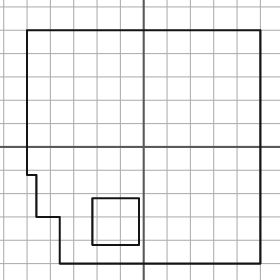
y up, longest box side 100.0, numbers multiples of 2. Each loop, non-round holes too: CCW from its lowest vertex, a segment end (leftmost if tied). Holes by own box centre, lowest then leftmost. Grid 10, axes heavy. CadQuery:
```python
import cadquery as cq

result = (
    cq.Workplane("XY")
    .moveTo(-36.0, -50.0)
    .lineTo(50.0, -50.0)
    .lineTo(50.0, 50.0)
    .lineTo(-50.0, 50.0)
    .lineTo(-50.0, -12.0)
    .lineTo(-46.0, -12.0)
    .lineTo(-46.0, -30.0)
    .lineTo(-36.0, -30.0)
    .close()
    .moveTo(-22.0, -42.0)
    .lineTo(-2.0, -42.0)
    .lineTo(-2.0, -22.0)
    .lineTo(-22.0, -22.0)
    .close()
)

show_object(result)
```